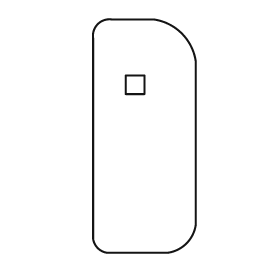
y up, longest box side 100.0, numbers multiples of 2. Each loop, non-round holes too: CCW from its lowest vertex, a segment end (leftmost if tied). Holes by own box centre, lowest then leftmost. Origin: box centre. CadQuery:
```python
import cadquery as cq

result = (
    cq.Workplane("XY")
    .moveTo(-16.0, -50.0)
    .lineTo(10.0, -50.0)
    .threePointArc((18.0, -46.0), (22.0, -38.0))
    .lineTo(22.0, 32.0)
    .threePointArc((16.0, 44.0), (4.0, 50.0))
    .lineTo(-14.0, 50.0)
    .threePointArc((-20.0, 48.0), (-22.0, 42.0))
    .lineTo(-22.0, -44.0)
    .threePointArc((-20.0, -48.0), (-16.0, -50.0))
    .close()
    .moveTo(-8.0, 18.0)
    .lineTo(0.0, 18.0)
    .lineTo(0.0, 26.0)
    .lineTo(-8.0, 26.0)
    .close()
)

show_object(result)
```